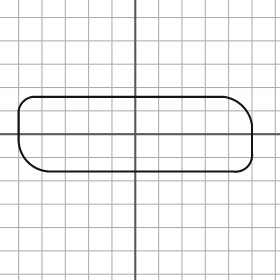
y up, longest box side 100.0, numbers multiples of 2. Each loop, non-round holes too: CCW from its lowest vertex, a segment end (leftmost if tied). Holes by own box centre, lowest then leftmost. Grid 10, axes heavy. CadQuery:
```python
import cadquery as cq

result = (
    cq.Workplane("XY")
    .moveTo(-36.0, -16.0)
    .lineTo(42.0, -16.0)
    .threePointArc((48.0, -14.0), (50.0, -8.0))
    .lineTo(50.0, 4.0)
    .threePointArc((46.0, 12.0), (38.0, 16.0))
    .lineTo(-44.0, 16.0)
    .threePointArc((-48.0, 14.0), (-50.0, 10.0))
    .lineTo(-50.0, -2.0)
    .threePointArc((-46.0, -12.0), (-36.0, -16.0))
    .close()
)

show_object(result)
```